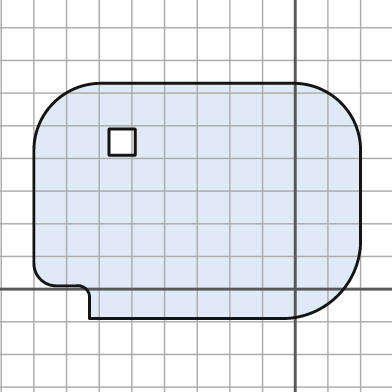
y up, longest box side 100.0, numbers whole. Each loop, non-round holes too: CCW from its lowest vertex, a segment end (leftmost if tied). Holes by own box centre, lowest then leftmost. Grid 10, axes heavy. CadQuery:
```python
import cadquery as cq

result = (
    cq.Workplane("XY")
    .moveTo(-63.0, -9.0)
    .lineTo(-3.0, -9.0)
    .threePointArc((13.0, -2.0), (20.0, 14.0))
    .lineTo(20.0, 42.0)
    .threePointArc((14.0, 57.0), (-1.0, 63.0))
    .lineTo(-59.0, 63.0)
    .threePointArc((-74.0, 57.0), (-80.0, 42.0))
    .lineTo(-80.0, 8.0)
    .threePointArc((-78.0, 3.0), (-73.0, 1.0))
    .lineTo(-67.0, 1.0)
    .threePointArc((-64.0, 0.0), (-63.0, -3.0))
    .close()
    .moveTo(-57.0, 41.0)
    .lineTo(-49.0, 41.0)
    .lineTo(-49.0, 49.0)
    .lineTo(-57.0, 49.0)
    .close()
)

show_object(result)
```